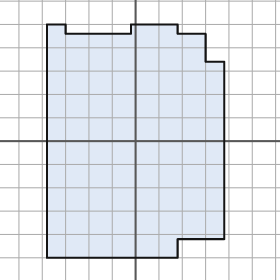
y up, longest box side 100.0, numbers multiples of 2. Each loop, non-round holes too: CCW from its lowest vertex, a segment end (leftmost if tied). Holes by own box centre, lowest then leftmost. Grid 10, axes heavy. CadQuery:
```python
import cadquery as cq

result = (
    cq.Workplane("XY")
    .moveTo(-38.0, -50.0)
    .lineTo(18.0, -50.0)
    .lineTo(18.0, -42.0)
    .lineTo(38.0, -42.0)
    .lineTo(38.0, 34.0)
    .lineTo(30.0, 34.0)
    .lineTo(30.0, 46.0)
    .lineTo(18.0, 46.0)
    .lineTo(18.0, 50.0)
    .lineTo(-2.0, 50.0)
    .lineTo(-2.0, 46.0)
    .lineTo(-30.0, 46.0)
    .lineTo(-30.0, 50.0)
    .lineTo(-38.0, 50.0)
    .close()
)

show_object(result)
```